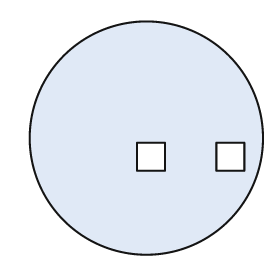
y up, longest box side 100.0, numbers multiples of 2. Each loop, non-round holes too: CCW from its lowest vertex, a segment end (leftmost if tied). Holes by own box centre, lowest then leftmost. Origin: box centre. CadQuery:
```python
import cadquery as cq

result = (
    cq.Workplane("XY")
    .moveTo(0.0, 0.0)
    .circle(50.0)
    .moveTo(-4.0, -14.0)
    .lineTo(8.0, -14.0)
    .lineTo(8.0, -2.0)
    .lineTo(-4.0, -2.0)
    .close()
    .moveTo(30.0, -14.0)
    .lineTo(42.0, -14.0)
    .lineTo(42.0, -2.0)
    .lineTo(30.0, -2.0)
    .close()
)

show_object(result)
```